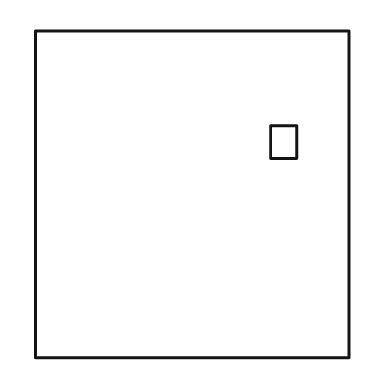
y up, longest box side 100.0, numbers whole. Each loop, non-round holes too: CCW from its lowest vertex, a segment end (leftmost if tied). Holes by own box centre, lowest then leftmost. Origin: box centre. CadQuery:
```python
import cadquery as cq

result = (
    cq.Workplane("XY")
    .moveTo(-48.0, -50.0)
    .lineTo(48.0, -50.0)
    .lineTo(48.0, 50.0)
    .lineTo(-48.0, 50.0)
    .close()
    .moveTo(24.0, 11.0)
    .lineTo(32.0, 11.0)
    .lineTo(32.0, 21.0)
    .lineTo(24.0, 21.0)
    .close()
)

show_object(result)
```